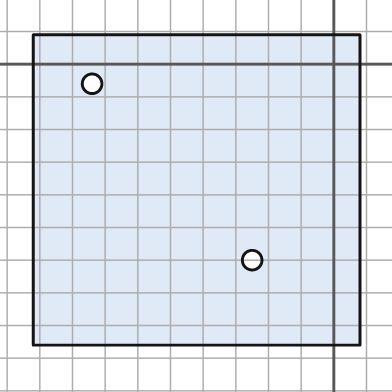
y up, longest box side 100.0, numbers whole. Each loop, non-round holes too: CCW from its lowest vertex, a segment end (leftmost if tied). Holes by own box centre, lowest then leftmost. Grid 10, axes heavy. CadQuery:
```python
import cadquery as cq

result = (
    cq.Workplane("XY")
    .moveTo(-92.0, -86.0)
    .lineTo(8.0, -86.0)
    .lineTo(8.0, 9.0)
    .lineTo(-92.0, 9.0)
    .close()
    .moveTo(-25.0, -60.0)
    .circle(3.0)
    .moveTo(-74.0, -6.0)
    .circle(3.0)
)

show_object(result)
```